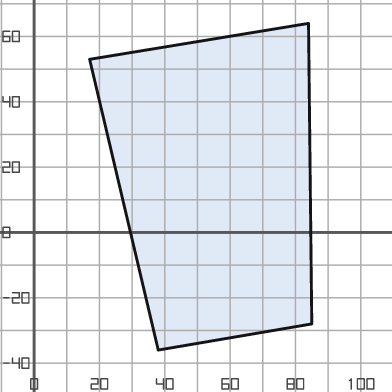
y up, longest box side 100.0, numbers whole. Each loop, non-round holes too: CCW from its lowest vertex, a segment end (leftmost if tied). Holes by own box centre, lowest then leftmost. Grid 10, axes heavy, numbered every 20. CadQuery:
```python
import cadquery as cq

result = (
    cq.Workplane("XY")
    .moveTo(38.0, -36.0)
    .lineTo(85.0, -28.0)
    .lineTo(84.0, 64.0)
    .lineTo(17.0, 53.0)
    .close()
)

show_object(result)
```